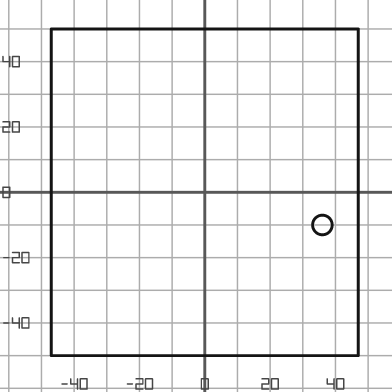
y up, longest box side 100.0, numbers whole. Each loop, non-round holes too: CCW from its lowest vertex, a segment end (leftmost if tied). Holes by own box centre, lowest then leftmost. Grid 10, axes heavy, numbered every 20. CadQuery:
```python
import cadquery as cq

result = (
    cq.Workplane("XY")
    .moveTo(-47.0, -50.0)
    .lineTo(47.0, -50.0)
    .lineTo(47.0, 50.0)
    .lineTo(-47.0, 50.0)
    .close()
    .moveTo(36.0, -10.0)
    .circle(3.0)
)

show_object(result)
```